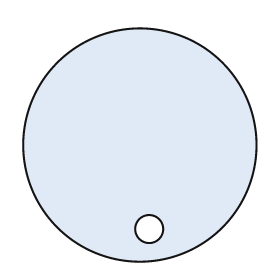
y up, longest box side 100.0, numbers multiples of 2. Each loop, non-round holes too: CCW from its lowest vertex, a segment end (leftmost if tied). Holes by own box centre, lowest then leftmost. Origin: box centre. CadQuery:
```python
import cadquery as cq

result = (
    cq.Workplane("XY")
    .moveTo(0.0, 0.0)
    .circle(50.0)
    .moveTo(4.0, -36.0)
    .circle(6.0)
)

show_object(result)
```